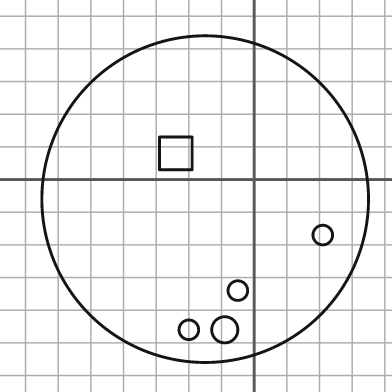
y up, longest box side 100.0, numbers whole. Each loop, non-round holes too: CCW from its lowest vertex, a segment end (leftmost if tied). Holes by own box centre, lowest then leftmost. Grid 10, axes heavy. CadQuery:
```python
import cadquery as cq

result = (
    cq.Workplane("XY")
    .moveTo(-15.0, -6.0)
    .circle(50.0)
    .moveTo(-20.0, -46.0)
    .circle(3.0)
    .moveTo(-9.0, -46.0)
    .circle(4.0)
    .moveTo(-5.0, -34.0)
    .circle(3.0)
    .moveTo(21.0, -17.0)
    .circle(3.0)
    .moveTo(-29.0, 3.0)
    .lineTo(-19.0, 3.0)
    .lineTo(-19.0, 13.0)
    .lineTo(-29.0, 13.0)
    .close()
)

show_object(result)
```